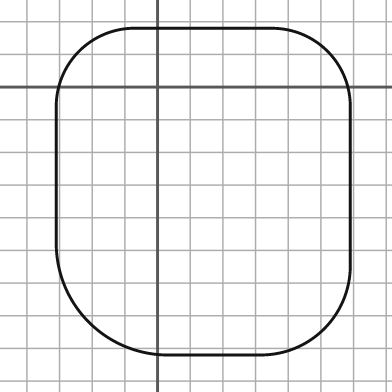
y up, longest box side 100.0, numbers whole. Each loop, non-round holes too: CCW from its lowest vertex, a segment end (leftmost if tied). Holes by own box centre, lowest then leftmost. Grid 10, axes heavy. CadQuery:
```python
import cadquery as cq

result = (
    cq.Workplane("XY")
    .moveTo(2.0, -82.0)
    .lineTo(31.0, -82.0)
    .threePointArc((51.0, -74.0), (59.0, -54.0))
    .lineTo(59.0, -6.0)
    .threePointArc((52.0, 11.0), (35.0, 18.0))
    .lineTo(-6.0, 18.0)
    .threePointArc((-24.0, 11.0), (-31.0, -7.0))
    .lineTo(-31.0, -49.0)
    .threePointArc((-21.0, -72.0), (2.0, -82.0))
    .close()
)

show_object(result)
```